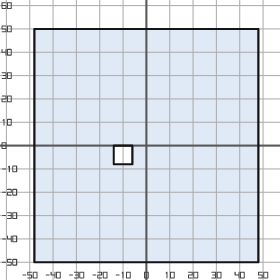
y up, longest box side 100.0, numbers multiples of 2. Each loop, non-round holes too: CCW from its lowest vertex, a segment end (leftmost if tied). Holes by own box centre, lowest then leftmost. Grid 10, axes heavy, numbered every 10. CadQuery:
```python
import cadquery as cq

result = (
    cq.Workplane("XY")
    .moveTo(-48.0, -50.0)
    .lineTo(48.0, -50.0)
    .lineTo(48.0, 50.0)
    .lineTo(-48.0, 50.0)
    .close()
    .moveTo(-14.0, -8.0)
    .lineTo(-6.0, -8.0)
    .lineTo(-6.0, 0.0)
    .lineTo(-14.0, 0.0)
    .close()
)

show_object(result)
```